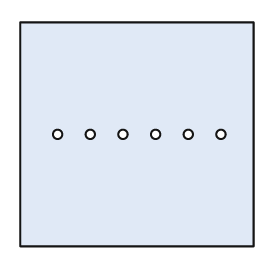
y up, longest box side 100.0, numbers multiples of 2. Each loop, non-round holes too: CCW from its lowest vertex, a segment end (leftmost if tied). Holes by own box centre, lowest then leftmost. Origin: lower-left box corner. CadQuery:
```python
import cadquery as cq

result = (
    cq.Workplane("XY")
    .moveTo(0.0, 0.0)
    .lineTo(100.0, 0.0)
    .lineTo(100.0, 96.0)
    .lineTo(0.0, 96.0)
    .close()
    .moveTo(16.0, 48.0)
    .circle(2.0)
    .moveTo(30.0, 48.0)
    .circle(2.0)
    .moveTo(44.0, 48.0)
    .circle(2.0)
    .moveTo(58.0, 48.0)
    .circle(2.0)
    .moveTo(72.0, 48.0)
    .circle(2.0)
    .moveTo(86.0, 48.0)
    .circle(2.0)
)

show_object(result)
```